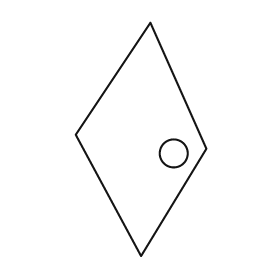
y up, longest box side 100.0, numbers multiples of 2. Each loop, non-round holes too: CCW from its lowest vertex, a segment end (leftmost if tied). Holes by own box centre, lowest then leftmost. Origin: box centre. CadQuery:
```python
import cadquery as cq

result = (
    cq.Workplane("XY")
    .moveTo(0.0, -50.0)
    .lineTo(28.0, -4.0)
    .lineTo(4.0, 50.0)
    .lineTo(-28.0, 2.0)
    .close()
    .moveTo(14.0, -6.0)
    .circle(6.0)
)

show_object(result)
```